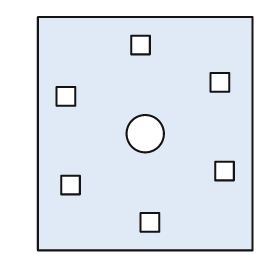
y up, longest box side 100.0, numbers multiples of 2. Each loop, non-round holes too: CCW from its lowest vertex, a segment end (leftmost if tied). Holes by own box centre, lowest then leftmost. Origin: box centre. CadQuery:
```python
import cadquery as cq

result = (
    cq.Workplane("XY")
    .moveTo(-46.0, -50.0)
    .lineTo(46.0, -50.0)
    .lineTo(46.0, 50.0)
    .lineTo(-46.0, 50.0)
    .close()
    .moveTo(-2.0, -42.0)
    .lineTo(6.0, -42.0)
    .lineTo(6.0, -34.0)
    .lineTo(-2.0, -34.0)
    .close()
    .moveTo(-36.0, -26.0)
    .lineTo(-28.0, -26.0)
    .lineTo(-28.0, -18.0)
    .lineTo(-36.0, -18.0)
    .close()
    .moveTo(30.0, -20.0)
    .lineTo(38.0, -20.0)
    .lineTo(38.0, -12.0)
    .lineTo(30.0, -12.0)
    .close()
    .moveTo(0.0, 0.0)
    .circle(8.0)
    .moveTo(-38.0, 12.0)
    .lineTo(-30.0, 12.0)
    .lineTo(-30.0, 20.0)
    .lineTo(-38.0, 20.0)
    .close()
    .moveTo(28.0, 18.0)
    .lineTo(36.0, 18.0)
    .lineTo(36.0, 26.0)
    .lineTo(28.0, 26.0)
    .close()
    .moveTo(-6.0, 34.0)
    .lineTo(2.0, 34.0)
    .lineTo(2.0, 42.0)
    .lineTo(-6.0, 42.0)
    .close()
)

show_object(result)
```